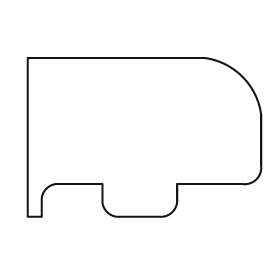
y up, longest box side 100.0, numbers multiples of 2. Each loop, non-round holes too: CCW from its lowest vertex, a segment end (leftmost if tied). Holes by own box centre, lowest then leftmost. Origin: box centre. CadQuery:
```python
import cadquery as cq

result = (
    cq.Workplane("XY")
    .moveTo(-50.0, -34.0)
    .lineTo(-44.0, -34.0)
    .lineTo(-44.0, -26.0)
    .threePointArc((-42.0, -22.0), (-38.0, -20.0))
    .lineTo(-18.0, -20.0)
    .lineTo(-18.0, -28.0)
    .threePointArc((-16.0, -32.0), (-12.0, -34.0))
    .lineTo(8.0, -34.0)
    .threePointArc((12.0, -32.0), (14.0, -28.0))
    .lineTo(14.0, -20.0)
    .lineTo(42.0, -20.0)
    .threePointArc((48.0, -18.0), (50.0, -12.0))
    .lineTo(50.0, 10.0)
    .threePointArc((42.0, 26.0), (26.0, 34.0))
    .lineTo(-50.0, 34.0)
    .close()
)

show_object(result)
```